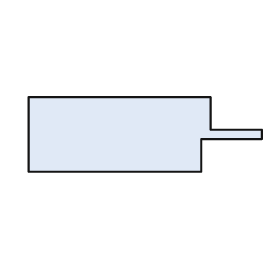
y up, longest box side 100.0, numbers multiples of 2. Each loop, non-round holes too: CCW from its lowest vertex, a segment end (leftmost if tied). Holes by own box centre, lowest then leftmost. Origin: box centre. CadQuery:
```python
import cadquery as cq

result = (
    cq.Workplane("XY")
    .moveTo(-50.0, -16.0)
    .lineTo(24.0, -16.0)
    .lineTo(24.0, -2.0)
    .lineTo(50.0, -2.0)
    .lineTo(50.0, 2.0)
    .lineTo(28.0, 2.0)
    .lineTo(28.0, 16.0)
    .lineTo(-50.0, 16.0)
    .close()
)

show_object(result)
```